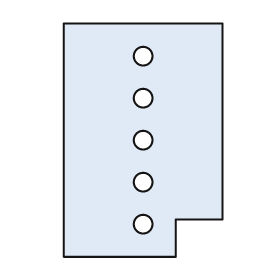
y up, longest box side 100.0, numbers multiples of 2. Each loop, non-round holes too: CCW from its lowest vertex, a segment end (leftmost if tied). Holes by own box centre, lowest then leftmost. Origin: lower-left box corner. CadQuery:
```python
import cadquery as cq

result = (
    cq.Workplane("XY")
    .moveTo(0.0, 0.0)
    .lineTo(48.0, 0.0)
    .lineTo(48.0, 16.0)
    .lineTo(68.0, 16.0)
    .lineTo(68.0, 100.0)
    .lineTo(0.0, 100.0)
    .close()
    .moveTo(34.0, 14.0)
    .circle(4.0)
    .moveTo(34.0, 32.0)
    .circle(4.0)
    .moveTo(34.0, 50.0)
    .circle(4.0)
    .moveTo(34.0, 68.0)
    .circle(4.0)
    .moveTo(34.0, 86.0)
    .circle(4.0)
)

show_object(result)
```